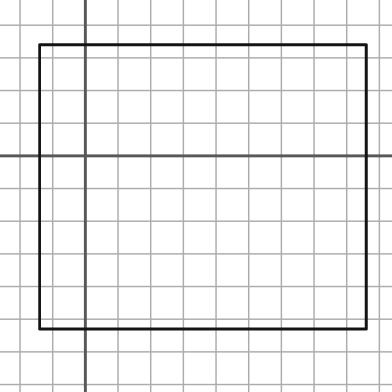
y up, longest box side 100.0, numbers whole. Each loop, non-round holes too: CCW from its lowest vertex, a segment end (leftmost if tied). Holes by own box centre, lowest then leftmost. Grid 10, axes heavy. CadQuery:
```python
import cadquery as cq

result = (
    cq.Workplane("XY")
    .moveTo(-14.0, -53.0)
    .lineTo(86.0, -53.0)
    .lineTo(86.0, 34.0)
    .lineTo(-14.0, 34.0)
    .close()
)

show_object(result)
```